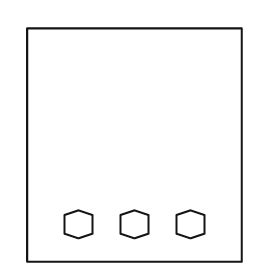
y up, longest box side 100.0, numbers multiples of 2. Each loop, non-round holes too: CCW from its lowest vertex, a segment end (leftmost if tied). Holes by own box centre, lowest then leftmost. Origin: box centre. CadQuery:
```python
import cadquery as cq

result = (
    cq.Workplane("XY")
    .moveTo(-46.0, -50.0)
    .lineTo(46.0, -50.0)
    .lineTo(46.0, 50.0)
    .lineTo(-46.0, 50.0)
    .close()
    .moveTo(-24.0, -40.0)
    .lineTo(-18.0, -38.0)
    .lineTo(-18.0, -30.0)
    .lineTo(-24.0, -28.0)
    .lineTo(-30.0, -30.0)
    .lineTo(-30.0, -38.0)
    .close()
    .moveTo(0.0, -40.0)
    .lineTo(6.0, -38.0)
    .lineTo(6.0, -30.0)
    .lineTo(0.0, -28.0)
    .lineTo(-6.0, -30.0)
    .lineTo(-6.0, -38.0)
    .close()
    .moveTo(24.0, -40.0)
    .lineTo(30.0, -38.0)
    .lineTo(30.0, -30.0)
    .lineTo(24.0, -28.0)
    .lineTo(18.0, -30.0)
    .lineTo(18.0, -38.0)
    .close()
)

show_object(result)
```